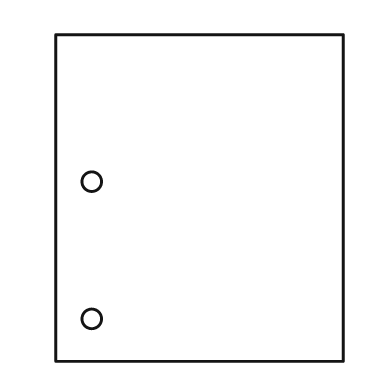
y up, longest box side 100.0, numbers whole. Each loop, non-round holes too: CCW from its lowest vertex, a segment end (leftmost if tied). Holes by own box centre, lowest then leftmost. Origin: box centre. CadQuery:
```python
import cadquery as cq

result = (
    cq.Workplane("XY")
    .moveTo(-44.0, -50.0)
    .lineTo(44.0, -50.0)
    .lineTo(44.0, 50.0)
    .lineTo(-44.0, 50.0)
    .close()
    .moveTo(-33.0, -37.0)
    .circle(3.0)
    .moveTo(-33.0, 5.0)
    .circle(3.0)
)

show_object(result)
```